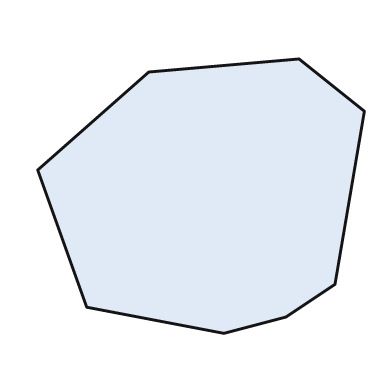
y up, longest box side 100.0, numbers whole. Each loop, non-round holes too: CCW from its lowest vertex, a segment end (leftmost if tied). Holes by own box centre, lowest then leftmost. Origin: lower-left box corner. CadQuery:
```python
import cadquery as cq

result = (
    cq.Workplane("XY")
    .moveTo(57.0, 0.0)
    .lineTo(76.0, 5.0)
    .lineTo(91.0, 15.0)
    .lineTo(100.0, 68.0)
    .lineTo(80.0, 84.0)
    .lineTo(34.0, 80.0)
    .lineTo(0.0, 50.0)
    .lineTo(15.0, 8.0)
    .close()
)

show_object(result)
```